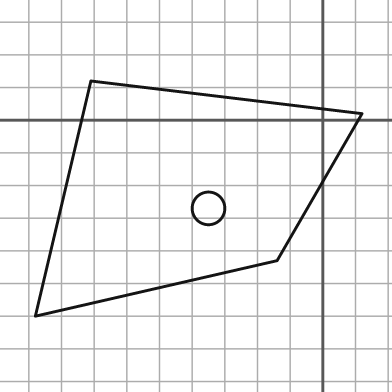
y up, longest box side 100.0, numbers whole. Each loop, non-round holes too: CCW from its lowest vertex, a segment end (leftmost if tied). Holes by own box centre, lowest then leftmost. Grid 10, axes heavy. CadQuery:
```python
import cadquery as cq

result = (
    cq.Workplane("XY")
    .moveTo(-88.0, -60.0)
    .lineTo(-14.0, -43.0)
    .lineTo(12.0, 2.0)
    .lineTo(-71.0, 12.0)
    .close()
    .moveTo(-35.0, -27.0)
    .circle(5.0)
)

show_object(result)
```